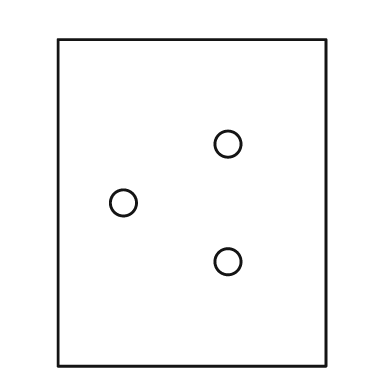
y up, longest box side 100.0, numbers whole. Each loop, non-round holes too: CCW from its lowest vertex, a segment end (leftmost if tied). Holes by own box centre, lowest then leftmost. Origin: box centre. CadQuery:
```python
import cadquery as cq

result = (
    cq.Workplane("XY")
    .moveTo(-41.0, -50.0)
    .lineTo(41.0, -50.0)
    .lineTo(41.0, 50.0)
    .lineTo(-41.0, 50.0)
    .close()
    .moveTo(11.0, -18.0)
    .circle(4.0)
    .moveTo(-21.0, 0.0)
    .circle(4.0)
    .moveTo(11.0, 18.0)
    .circle(4.0)
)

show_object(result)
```